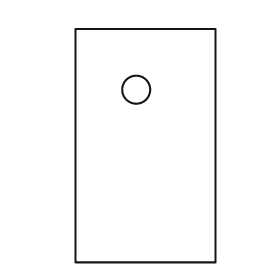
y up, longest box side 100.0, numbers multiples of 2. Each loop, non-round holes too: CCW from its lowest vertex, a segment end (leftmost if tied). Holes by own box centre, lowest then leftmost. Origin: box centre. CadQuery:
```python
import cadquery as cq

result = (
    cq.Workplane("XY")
    .moveTo(-30.0, -50.0)
    .lineTo(30.0, -50.0)
    .lineTo(30.0, 50.0)
    .lineTo(-30.0, 50.0)
    .close()
    .moveTo(-4.0, 24.0)
    .circle(6.0)
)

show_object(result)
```